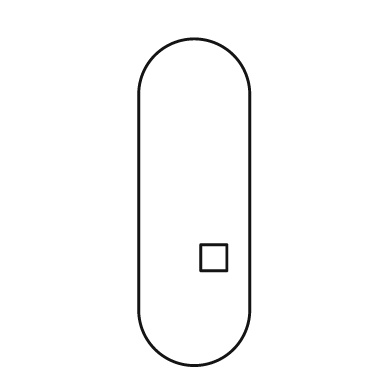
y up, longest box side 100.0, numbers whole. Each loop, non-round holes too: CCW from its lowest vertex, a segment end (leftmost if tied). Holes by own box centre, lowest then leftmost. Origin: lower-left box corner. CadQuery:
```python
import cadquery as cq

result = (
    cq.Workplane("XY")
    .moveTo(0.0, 17.0)
    .threePointArc((17.0, 0.0), (34.0, 17.0))
    .lineTo(34.0, 83.0)
    .threePointArc((17.0, 100.0), (0.0, 83.0))
    .close()
    .moveTo(19.0, 29.0)
    .lineTo(27.0, 29.0)
    .lineTo(27.0, 37.0)
    .lineTo(19.0, 37.0)
    .close()
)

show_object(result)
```